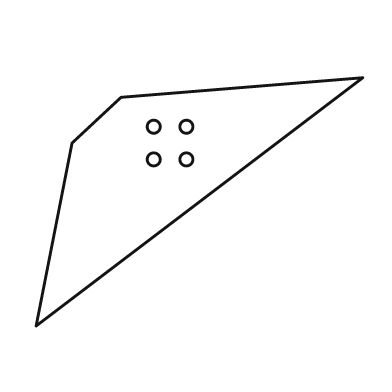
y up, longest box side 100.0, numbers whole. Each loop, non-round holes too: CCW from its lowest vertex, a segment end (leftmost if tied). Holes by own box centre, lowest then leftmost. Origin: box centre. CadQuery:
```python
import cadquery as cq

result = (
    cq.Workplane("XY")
    .moveTo(-50.0, -38.0)
    .lineTo(50.0, 38.0)
    .lineTo(-24.0, 32.0)
    .lineTo(-39.0, 18.0)
    .close()
    .moveTo(-14.0, 13.0)
    .circle(2.0)
    .moveTo(-4.0, 13.0)
    .circle(2.0)
    .moveTo(-14.0, 23.0)
    .circle(2.0)
    .moveTo(-4.0, 23.0)
    .circle(2.0)
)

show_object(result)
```